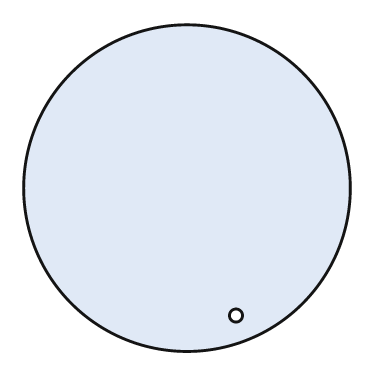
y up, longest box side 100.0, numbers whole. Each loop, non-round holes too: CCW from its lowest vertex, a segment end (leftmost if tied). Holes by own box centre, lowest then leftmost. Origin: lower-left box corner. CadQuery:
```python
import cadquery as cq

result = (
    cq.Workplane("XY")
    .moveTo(50.0, 50.0)
    .circle(50.0)
    .moveTo(65.0, 11.0)
    .circle(2.0)
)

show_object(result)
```